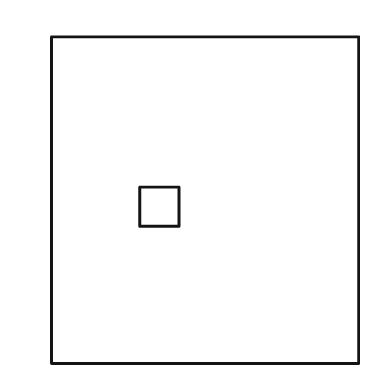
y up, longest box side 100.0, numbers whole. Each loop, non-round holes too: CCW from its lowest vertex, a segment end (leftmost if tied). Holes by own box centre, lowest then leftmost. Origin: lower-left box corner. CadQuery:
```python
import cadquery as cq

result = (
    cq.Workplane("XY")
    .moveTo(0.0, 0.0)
    .lineTo(94.0, 0.0)
    .lineTo(94.0, 100.0)
    .lineTo(0.0, 100.0)
    .close()
    .moveTo(27.0, 42.0)
    .lineTo(39.0, 42.0)
    .lineTo(39.0, 54.0)
    .lineTo(27.0, 54.0)
    .close()
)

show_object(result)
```